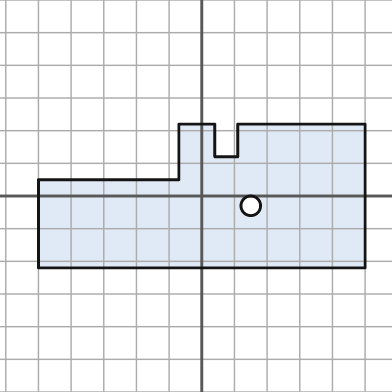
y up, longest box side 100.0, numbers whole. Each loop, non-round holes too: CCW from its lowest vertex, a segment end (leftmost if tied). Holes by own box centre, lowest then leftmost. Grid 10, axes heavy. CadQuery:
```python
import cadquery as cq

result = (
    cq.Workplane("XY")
    .moveTo(-50.0, -22.0)
    .lineTo(50.0, -22.0)
    .lineTo(50.0, 22.0)
    .lineTo(11.0, 22.0)
    .lineTo(11.0, 12.0)
    .lineTo(4.0, 12.0)
    .lineTo(4.0, 22.0)
    .lineTo(-7.0, 22.0)
    .lineTo(-7.0, 5.0)
    .lineTo(-50.0, 5.0)
    .close()
    .moveTo(15.0, -3.0)
    .circle(3.0)
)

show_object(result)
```